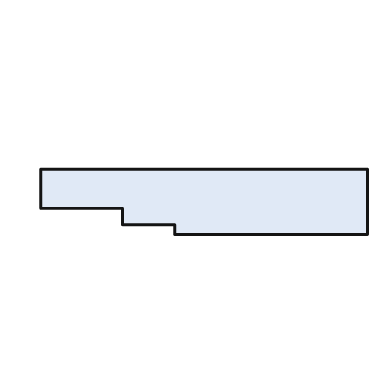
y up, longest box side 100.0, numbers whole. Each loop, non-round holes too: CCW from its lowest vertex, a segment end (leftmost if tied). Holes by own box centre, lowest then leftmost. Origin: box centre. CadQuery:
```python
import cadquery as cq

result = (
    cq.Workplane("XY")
    .moveTo(-9.0, -10.0)
    .lineTo(50.0, -10.0)
    .lineTo(50.0, 10.0)
    .lineTo(-50.0, 10.0)
    .lineTo(-50.0, -2.0)
    .lineTo(-25.0, -2.0)
    .lineTo(-25.0, -7.0)
    .lineTo(-9.0, -7.0)
    .close()
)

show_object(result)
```